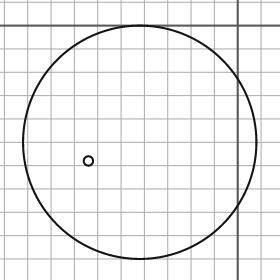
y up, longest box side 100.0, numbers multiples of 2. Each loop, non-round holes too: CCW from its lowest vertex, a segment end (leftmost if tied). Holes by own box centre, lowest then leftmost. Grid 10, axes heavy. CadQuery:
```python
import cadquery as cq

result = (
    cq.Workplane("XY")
    .moveTo(-42.0, -50.0)
    .circle(50.0)
    .moveTo(-64.0, -58.0)
    .circle(2.0)
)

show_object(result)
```